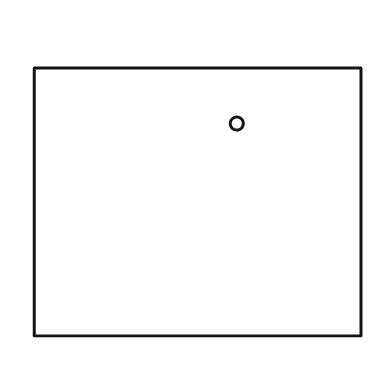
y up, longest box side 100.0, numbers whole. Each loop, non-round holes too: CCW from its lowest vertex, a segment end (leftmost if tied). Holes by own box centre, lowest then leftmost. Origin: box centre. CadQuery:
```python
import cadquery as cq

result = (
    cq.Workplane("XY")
    .moveTo(-50.0, -41.0)
    .lineTo(50.0, -41.0)
    .lineTo(50.0, 41.0)
    .lineTo(-50.0, 41.0)
    .close()
    .moveTo(12.0, 24.0)
    .circle(2.0)
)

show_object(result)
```